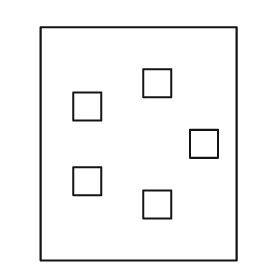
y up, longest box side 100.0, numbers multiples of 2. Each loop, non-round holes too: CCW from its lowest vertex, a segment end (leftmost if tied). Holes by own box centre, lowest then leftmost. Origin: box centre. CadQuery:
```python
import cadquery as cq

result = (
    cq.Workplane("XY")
    .moveTo(-42.0, -50.0)
    .lineTo(42.0, -50.0)
    .lineTo(42.0, 50.0)
    .lineTo(-42.0, 50.0)
    .close()
    .moveTo(2.0, -32.0)
    .lineTo(14.0, -32.0)
    .lineTo(14.0, -20.0)
    .lineTo(2.0, -20.0)
    .close()
    .moveTo(-28.0, -22.0)
    .lineTo(-16.0, -22.0)
    .lineTo(-16.0, -10.0)
    .lineTo(-28.0, -10.0)
    .close()
    .moveTo(22.0, -6.0)
    .lineTo(34.0, -6.0)
    .lineTo(34.0, 6.0)
    .lineTo(22.0, 6.0)
    .close()
    .moveTo(-28.0, 10.0)
    .lineTo(-16.0, 10.0)
    .lineTo(-16.0, 22.0)
    .lineTo(-28.0, 22.0)
    .close()
    .moveTo(2.0, 20.0)
    .lineTo(14.0, 20.0)
    .lineTo(14.0, 32.0)
    .lineTo(2.0, 32.0)
    .close()
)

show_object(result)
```